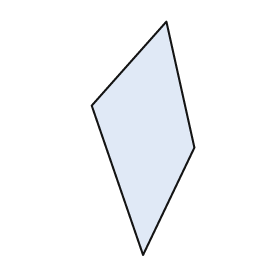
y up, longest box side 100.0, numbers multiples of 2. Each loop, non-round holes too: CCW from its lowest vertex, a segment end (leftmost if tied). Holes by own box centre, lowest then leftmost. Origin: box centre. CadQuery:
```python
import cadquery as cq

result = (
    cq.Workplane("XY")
    .moveTo(0.0, -50.0)
    .lineTo(22.0, -4.0)
    .lineTo(10.0, 50.0)
    .lineTo(-22.0, 14.0)
    .close()
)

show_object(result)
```